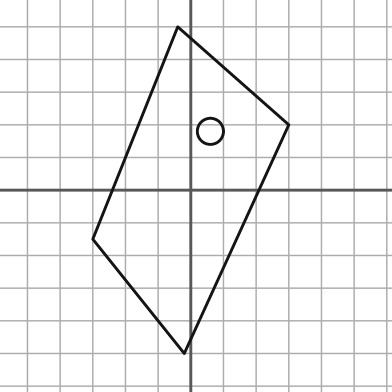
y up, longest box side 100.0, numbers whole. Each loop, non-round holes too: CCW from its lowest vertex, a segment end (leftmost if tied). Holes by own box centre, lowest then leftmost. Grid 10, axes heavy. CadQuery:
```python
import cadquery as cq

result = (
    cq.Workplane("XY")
    .moveTo(-2.0, -50.0)
    .lineTo(30.0, 20.0)
    .lineTo(-4.0, 50.0)
    .lineTo(-30.0, -15.0)
    .close()
    .moveTo(6.0, 18.0)
    .circle(4.0)
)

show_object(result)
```